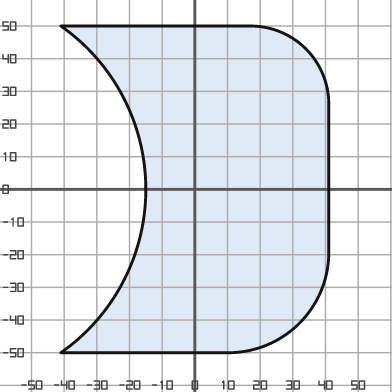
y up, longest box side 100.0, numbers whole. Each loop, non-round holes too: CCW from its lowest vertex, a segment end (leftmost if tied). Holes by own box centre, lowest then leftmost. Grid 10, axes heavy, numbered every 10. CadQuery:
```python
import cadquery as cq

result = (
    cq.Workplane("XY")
    .moveTo(-41.0, -50.0)
    .lineTo(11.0, -50.0)
    .threePointArc((32.0, -41.0), (41.0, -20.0))
    .lineTo(41.0, 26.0)
    .threePointArc((34.0, 43.0), (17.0, 50.0))
    .lineTo(-41.0, 50.0)
    .threePointArc((-15.0, 0.0), (-41.0, -50.0))
    .close()
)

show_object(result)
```